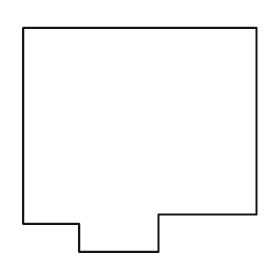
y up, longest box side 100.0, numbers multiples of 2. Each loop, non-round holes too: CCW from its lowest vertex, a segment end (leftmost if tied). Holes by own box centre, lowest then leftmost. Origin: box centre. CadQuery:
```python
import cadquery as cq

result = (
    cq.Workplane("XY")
    .moveTo(-26.0, -48.0)
    .lineTo(8.0, -48.0)
    .lineTo(8.0, -32.0)
    .lineTo(50.0, -32.0)
    .lineTo(50.0, 48.0)
    .lineTo(-50.0, 48.0)
    .lineTo(-50.0, -36.0)
    .lineTo(-26.0, -36.0)
    .close()
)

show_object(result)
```